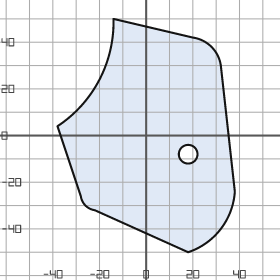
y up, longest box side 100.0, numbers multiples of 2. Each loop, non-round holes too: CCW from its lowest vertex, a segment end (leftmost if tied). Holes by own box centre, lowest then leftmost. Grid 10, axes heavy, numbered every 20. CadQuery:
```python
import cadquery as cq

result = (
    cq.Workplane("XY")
    .moveTo(18.0, -50.0)
    .threePointArc((32.0, -40.0), (38.0, -24.0))
    .lineTo(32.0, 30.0)
    .threePointArc((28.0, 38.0), (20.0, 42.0))
    .lineTo(-14.0, 50.0)
    .threePointArc((-20.0, 24.0), (-38.0, 4.0))
    .lineTo(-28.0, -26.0)
    .threePointArc((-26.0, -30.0), (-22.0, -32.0))
    .close()
    .moveTo(18.0, -8.0)
    .circle(4.0)
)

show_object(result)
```